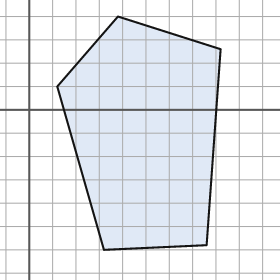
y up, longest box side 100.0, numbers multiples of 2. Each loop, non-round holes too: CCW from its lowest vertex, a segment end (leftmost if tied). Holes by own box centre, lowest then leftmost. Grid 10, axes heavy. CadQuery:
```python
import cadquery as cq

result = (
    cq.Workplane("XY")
    .moveTo(32.0, -60.0)
    .lineTo(76.0, -58.0)
    .lineTo(82.0, 26.0)
    .lineTo(38.0, 40.0)
    .lineTo(12.0, 10.0)
    .close()
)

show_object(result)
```